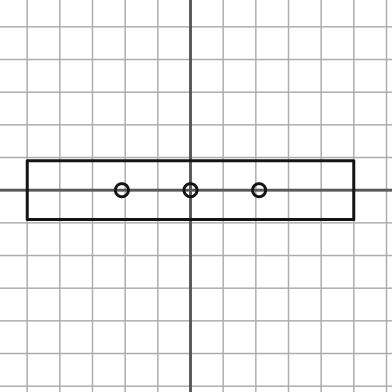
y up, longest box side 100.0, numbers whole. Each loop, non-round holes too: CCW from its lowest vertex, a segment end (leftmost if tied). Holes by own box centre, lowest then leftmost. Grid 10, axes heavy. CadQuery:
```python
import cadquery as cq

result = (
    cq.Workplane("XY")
    .moveTo(-50.0, -9.0)
    .lineTo(50.0, -9.0)
    .lineTo(50.0, 9.0)
    .lineTo(-50.0, 9.0)
    .close()
    .moveTo(-21.0, 0.0)
    .circle(2.0)
    .moveTo(0.0, 0.0)
    .circle(2.0)
    .moveTo(21.0, 0.0)
    .circle(2.0)
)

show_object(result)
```